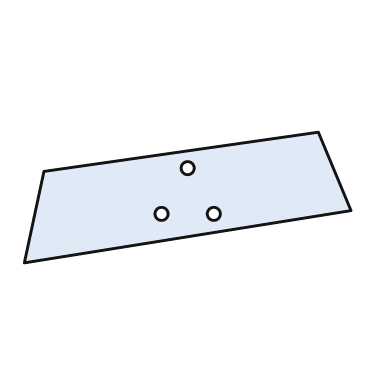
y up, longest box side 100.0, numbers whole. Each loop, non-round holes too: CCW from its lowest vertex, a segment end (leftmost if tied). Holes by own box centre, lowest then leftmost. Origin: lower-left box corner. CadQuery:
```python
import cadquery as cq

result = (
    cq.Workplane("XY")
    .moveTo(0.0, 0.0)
    .lineTo(100.0, 16.0)
    .lineTo(90.0, 40.0)
    .lineTo(6.0, 28.0)
    .close()
    .moveTo(42.0, 15.0)
    .circle(2.0)
    .moveTo(58.0, 15.0)
    .circle(2.0)
    .moveTo(50.0, 29.0)
    .circle(2.0)
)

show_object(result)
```